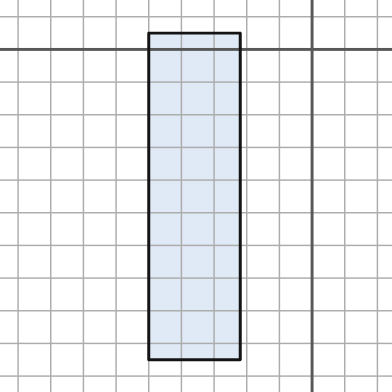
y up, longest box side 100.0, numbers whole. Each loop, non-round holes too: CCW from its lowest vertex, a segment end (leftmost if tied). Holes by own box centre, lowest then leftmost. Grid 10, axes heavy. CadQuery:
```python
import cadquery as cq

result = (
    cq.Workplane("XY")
    .moveTo(-50.0, -95.0)
    .lineTo(-22.0, -95.0)
    .lineTo(-22.0, 5.0)
    .lineTo(-50.0, 5.0)
    .close()
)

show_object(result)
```